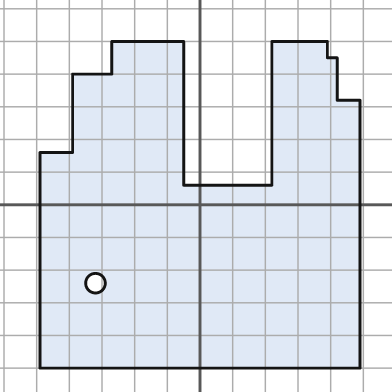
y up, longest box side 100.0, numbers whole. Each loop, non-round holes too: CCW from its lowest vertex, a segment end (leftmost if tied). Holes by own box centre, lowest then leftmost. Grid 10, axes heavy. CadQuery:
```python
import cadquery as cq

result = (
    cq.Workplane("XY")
    .moveTo(-49.0, -50.0)
    .lineTo(49.0, -50.0)
    .lineTo(49.0, 32.0)
    .lineTo(42.0, 32.0)
    .lineTo(42.0, 45.0)
    .lineTo(39.0, 45.0)
    .lineTo(39.0, 50.0)
    .lineTo(22.0, 50.0)
    .lineTo(22.0, 6.0)
    .lineTo(-5.0, 6.0)
    .lineTo(-5.0, 50.0)
    .lineTo(-27.0, 50.0)
    .lineTo(-27.0, 40.0)
    .lineTo(-39.0, 40.0)
    .lineTo(-39.0, 16.0)
    .lineTo(-49.0, 16.0)
    .close()
    .moveTo(-32.0, -24.0)
    .circle(3.0)
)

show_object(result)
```